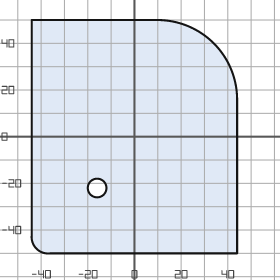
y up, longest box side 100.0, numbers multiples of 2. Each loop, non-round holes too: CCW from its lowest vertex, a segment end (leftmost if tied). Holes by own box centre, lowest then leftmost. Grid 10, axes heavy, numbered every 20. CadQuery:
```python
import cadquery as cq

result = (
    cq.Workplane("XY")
    .moveTo(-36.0, -50.0)
    .lineTo(44.0, -50.0)
    .lineTo(44.0, 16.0)
    .threePointArc((34.0, 40.0), (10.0, 50.0))
    .lineTo(-44.0, 50.0)
    .lineTo(-44.0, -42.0)
    .threePointArc((-42.0, -48.0), (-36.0, -50.0))
    .close()
    .moveTo(-16.0, -22.0)
    .circle(4.0)
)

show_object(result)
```